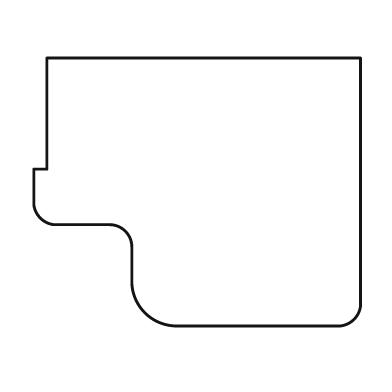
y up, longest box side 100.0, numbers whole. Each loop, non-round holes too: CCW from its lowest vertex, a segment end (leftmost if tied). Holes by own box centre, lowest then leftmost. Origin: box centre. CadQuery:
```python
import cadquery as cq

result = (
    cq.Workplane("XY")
    .moveTo(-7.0, -41.0)
    .lineTo(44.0, -41.0)
    .threePointArc((48.0, -39.0), (50.0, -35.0))
    .lineTo(50.0, 41.0)
    .lineTo(-46.0, 41.0)
    .lineTo(-46.0, 7.0)
    .lineTo(-50.0, 7.0)
    .lineTo(-50.0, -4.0)
    .threePointArc((-48.0, -8.0), (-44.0, -10.0))
    .lineTo(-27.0, -10.0)
    .threePointArc((-22.0, -12.0), (-20.0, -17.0))
    .lineTo(-20.0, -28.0)
    .threePointArc((-16.0, -37.0), (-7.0, -41.0))
    .close()
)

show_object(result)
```